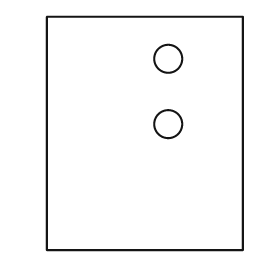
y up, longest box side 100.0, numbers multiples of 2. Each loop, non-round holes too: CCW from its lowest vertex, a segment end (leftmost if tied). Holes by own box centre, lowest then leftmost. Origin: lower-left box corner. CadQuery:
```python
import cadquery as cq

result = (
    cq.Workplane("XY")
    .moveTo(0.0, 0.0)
    .lineTo(84.0, 0.0)
    .lineTo(84.0, 100.0)
    .lineTo(0.0, 100.0)
    .close()
    .moveTo(52.0, 54.0)
    .circle(6.0)
    .moveTo(52.0, 82.0)
    .circle(6.0)
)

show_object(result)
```